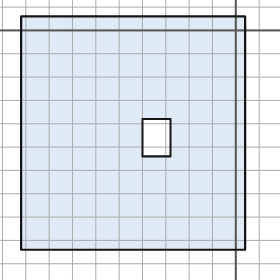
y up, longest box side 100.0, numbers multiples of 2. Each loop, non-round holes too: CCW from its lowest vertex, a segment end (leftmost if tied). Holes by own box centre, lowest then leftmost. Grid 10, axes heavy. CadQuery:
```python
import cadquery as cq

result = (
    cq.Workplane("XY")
    .moveTo(-92.0, -94.0)
    .lineTo(4.0, -94.0)
    .lineTo(4.0, 6.0)
    .lineTo(-92.0, 6.0)
    .close()
    .moveTo(-40.0, -54.0)
    .lineTo(-28.0, -54.0)
    .lineTo(-28.0, -38.0)
    .lineTo(-40.0, -38.0)
    .close()
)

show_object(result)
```